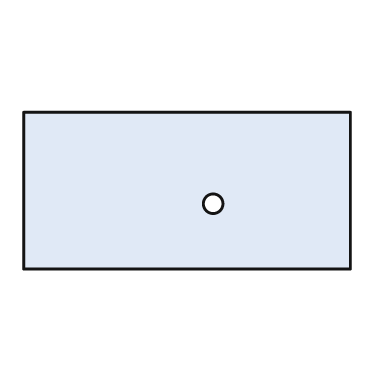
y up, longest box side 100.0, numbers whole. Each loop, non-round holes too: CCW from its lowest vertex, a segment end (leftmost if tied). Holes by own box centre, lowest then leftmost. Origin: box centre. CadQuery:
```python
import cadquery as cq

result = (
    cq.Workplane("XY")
    .moveTo(-50.0, -24.0)
    .lineTo(50.0, -24.0)
    .lineTo(50.0, 24.0)
    .lineTo(-50.0, 24.0)
    .close()
    .moveTo(8.0, -4.0)
    .circle(3.0)
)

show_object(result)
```